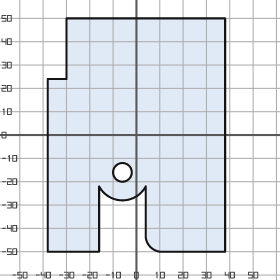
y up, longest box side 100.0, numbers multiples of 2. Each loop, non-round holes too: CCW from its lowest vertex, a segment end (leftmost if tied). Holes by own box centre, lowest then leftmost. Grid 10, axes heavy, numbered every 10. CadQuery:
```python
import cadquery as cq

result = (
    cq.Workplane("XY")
    .moveTo(-38.0, -50.0)
    .lineTo(-16.0, -50.0)
    .lineTo(-16.0, -22.0)
    .threePointArc((-6.0, -28.0), (4.0, -22.0))
    .lineTo(4.0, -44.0)
    .threePointArc((6.0, -48.0), (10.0, -50.0))
    .lineTo(38.0, -50.0)
    .lineTo(38.0, 50.0)
    .lineTo(-30.0, 50.0)
    .lineTo(-30.0, 24.0)
    .lineTo(-38.0, 24.0)
    .close()
    .moveTo(-6.0, -16.0)
    .circle(4.0)
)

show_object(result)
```